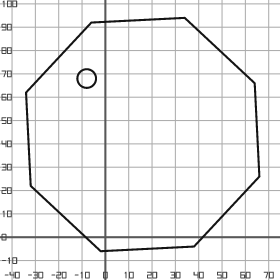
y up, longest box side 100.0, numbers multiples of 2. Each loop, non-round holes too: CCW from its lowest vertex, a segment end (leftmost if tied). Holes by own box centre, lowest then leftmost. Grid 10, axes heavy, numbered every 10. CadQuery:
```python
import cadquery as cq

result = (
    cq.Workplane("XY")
    .moveTo(-2.0, -6.0)
    .lineTo(38.0, -4.0)
    .lineTo(66.0, 26.0)
    .lineTo(64.0, 66.0)
    .lineTo(34.0, 94.0)
    .lineTo(-6.0, 92.0)
    .lineTo(-34.0, 62.0)
    .lineTo(-32.0, 22.0)
    .close()
    .moveTo(-8.0, 68.0)
    .circle(4.0)
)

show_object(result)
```